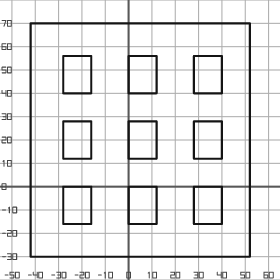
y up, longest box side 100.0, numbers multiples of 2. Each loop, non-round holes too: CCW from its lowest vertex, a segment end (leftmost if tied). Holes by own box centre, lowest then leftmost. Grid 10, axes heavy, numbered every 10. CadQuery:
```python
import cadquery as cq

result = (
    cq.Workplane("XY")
    .moveTo(-42.0, -30.0)
    .lineTo(52.0, -30.0)
    .lineTo(52.0, 70.0)
    .lineTo(-42.0, 70.0)
    .close()
    .moveTo(-28.0, -16.0)
    .lineTo(-16.0, -16.0)
    .lineTo(-16.0, 0.0)
    .lineTo(-28.0, 0.0)
    .close()
    .moveTo(0.0, -16.0)
    .lineTo(12.0, -16.0)
    .lineTo(12.0, 0.0)
    .lineTo(0.0, 0.0)
    .close()
    .moveTo(28.0, -16.0)
    .lineTo(40.0, -16.0)
    .lineTo(40.0, 0.0)
    .lineTo(28.0, 0.0)
    .close()
    .moveTo(-28.0, 12.0)
    .lineTo(-16.0, 12.0)
    .lineTo(-16.0, 28.0)
    .lineTo(-28.0, 28.0)
    .close()
    .moveTo(0.0, 12.0)
    .lineTo(12.0, 12.0)
    .lineTo(12.0, 28.0)
    .lineTo(0.0, 28.0)
    .close()
    .moveTo(28.0, 12.0)
    .lineTo(40.0, 12.0)
    .lineTo(40.0, 28.0)
    .lineTo(28.0, 28.0)
    .close()
    .moveTo(-28.0, 40.0)
    .lineTo(-16.0, 40.0)
    .lineTo(-16.0, 56.0)
    .lineTo(-28.0, 56.0)
    .close()
    .moveTo(0.0, 40.0)
    .lineTo(12.0, 40.0)
    .lineTo(12.0, 56.0)
    .lineTo(0.0, 56.0)
    .close()
    .moveTo(28.0, 40.0)
    .lineTo(40.0, 40.0)
    .lineTo(40.0, 56.0)
    .lineTo(28.0, 56.0)
    .close()
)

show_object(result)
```